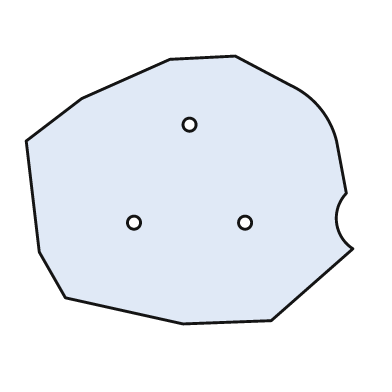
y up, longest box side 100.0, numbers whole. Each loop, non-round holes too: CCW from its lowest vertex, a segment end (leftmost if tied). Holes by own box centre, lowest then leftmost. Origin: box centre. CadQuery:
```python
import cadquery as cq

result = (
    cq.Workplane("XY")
    .moveTo(-2.0, -41.0)
    .lineTo(25.0, -40.0)
    .lineTo(50.0, -18.0)
    .threePointArc((45.0, -10.0), (48.0, -1.0))
    .lineTo(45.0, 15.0)
    .threePointArc((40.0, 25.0), (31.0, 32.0))
    .lineTo(14.0, 41.0)
    .lineTo(-6.0, 40.0)
    .lineTo(-33.0, 28.0)
    .lineTo(-50.0, 15.0)
    .lineTo(-46.0, -19.0)
    .lineTo(-38.0, -33.0)
    .close()
    .moveTo(-17.0, -10.0)
    .circle(2.0)
    .moveTo(17.0, -10.0)
    .circle(2.0)
    .moveTo(0.0, 20.0)
    .circle(2.0)
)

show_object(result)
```